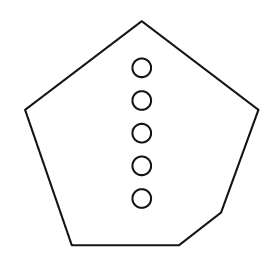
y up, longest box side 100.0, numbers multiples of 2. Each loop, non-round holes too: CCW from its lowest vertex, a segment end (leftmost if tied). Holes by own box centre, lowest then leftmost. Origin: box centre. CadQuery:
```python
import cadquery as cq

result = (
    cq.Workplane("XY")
    .moveTo(-30.0, -48.0)
    .lineTo(16.0, -48.0)
    .lineTo(34.0, -34.0)
    .lineTo(50.0, 10.0)
    .lineTo(0.0, 48.0)
    .lineTo(-50.0, 10.0)
    .close()
    .moveTo(0.0, -28.0)
    .circle(4.0)
    .moveTo(0.0, -14.0)
    .circle(4.0)
    .moveTo(0.0, 0.0)
    .circle(4.0)
    .moveTo(0.0, 14.0)
    .circle(4.0)
    .moveTo(0.0, 28.0)
    .circle(4.0)
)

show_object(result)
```